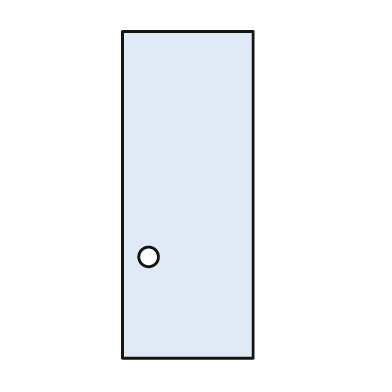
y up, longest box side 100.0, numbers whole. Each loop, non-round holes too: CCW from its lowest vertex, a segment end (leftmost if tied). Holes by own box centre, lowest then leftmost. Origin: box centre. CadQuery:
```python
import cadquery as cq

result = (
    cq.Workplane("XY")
    .moveTo(-20.0, -50.0)
    .lineTo(20.0, -50.0)
    .lineTo(20.0, 50.0)
    .lineTo(-20.0, 50.0)
    .close()
    .moveTo(-12.0, -19.0)
    .circle(3.0)
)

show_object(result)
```